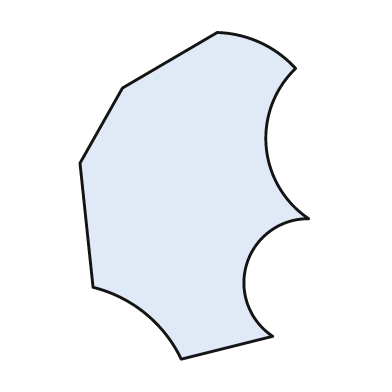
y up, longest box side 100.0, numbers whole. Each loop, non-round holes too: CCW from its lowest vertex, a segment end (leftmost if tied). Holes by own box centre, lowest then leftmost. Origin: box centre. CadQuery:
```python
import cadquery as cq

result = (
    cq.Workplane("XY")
    .moveTo(-4.0, -50.0)
    .lineTo(24.0, -43.0)
    .threePointArc((16.0, -21.0), (35.0, -7.0))
    .threePointArc((22.0, 15.0), (31.0, 39.0))
    .threePointArc((20.0, 47.0), (7.0, 50.0))
    .lineTo(-22.0, 33.0)
    .lineTo(-35.0, 10.0)
    .lineTo(-31.0, -28.0)
    .threePointArc((-15.0, -36.0), (-4.0, -50.0))
    .close()
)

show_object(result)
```